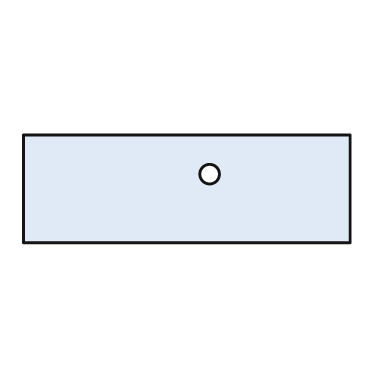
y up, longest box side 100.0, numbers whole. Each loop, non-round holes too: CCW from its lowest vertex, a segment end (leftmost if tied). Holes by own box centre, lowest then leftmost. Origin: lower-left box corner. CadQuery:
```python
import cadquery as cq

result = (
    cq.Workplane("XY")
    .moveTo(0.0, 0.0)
    .lineTo(100.0, 0.0)
    .lineTo(100.0, 33.0)
    .lineTo(0.0, 33.0)
    .close()
    .moveTo(57.0, 21.0)
    .circle(3.0)
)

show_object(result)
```